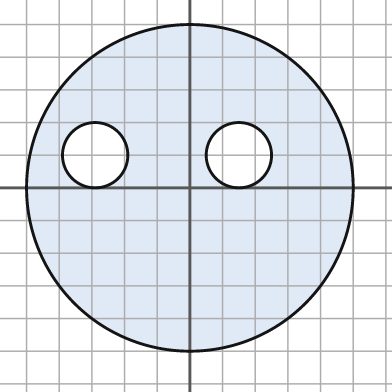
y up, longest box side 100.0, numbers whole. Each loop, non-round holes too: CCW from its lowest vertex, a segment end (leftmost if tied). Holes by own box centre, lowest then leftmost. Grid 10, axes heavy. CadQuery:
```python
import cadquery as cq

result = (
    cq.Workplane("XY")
    .moveTo(0.0, 0.0)
    .circle(50.0)
    .moveTo(-29.0, 10.0)
    .circle(10.0)
    .moveTo(15.0, 10.0)
    .circle(10.0)
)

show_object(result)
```